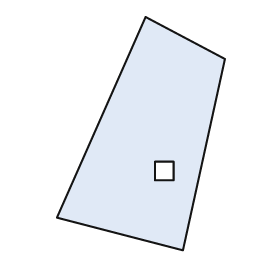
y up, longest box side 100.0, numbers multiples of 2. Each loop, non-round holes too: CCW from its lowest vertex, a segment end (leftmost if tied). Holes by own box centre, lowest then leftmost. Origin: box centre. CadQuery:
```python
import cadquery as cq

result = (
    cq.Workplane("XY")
    .moveTo(18.0, -50.0)
    .lineTo(36.0, 32.0)
    .lineTo(2.0, 50.0)
    .lineTo(-36.0, -36.0)
    .close()
    .moveTo(6.0, -20.0)
    .lineTo(14.0, -20.0)
    .lineTo(14.0, -12.0)
    .lineTo(6.0, -12.0)
    .close()
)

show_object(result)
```